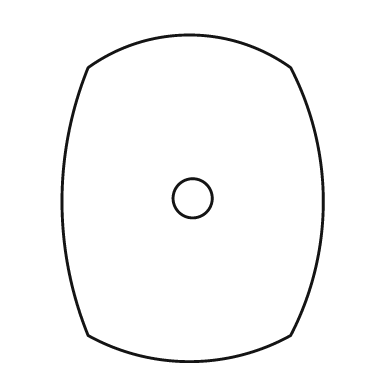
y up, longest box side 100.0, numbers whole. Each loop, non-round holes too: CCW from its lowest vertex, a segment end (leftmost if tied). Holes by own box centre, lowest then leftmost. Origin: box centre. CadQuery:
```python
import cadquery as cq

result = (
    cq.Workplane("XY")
    .moveTo(-32.0, -42.0)
    .threePointArc((-1.0, -50.0), (30.0, -42.0))
    .threePointArc((40.0, -1.0), (30.0, 40.0))
    .threePointArc((-1.0, 50.0), (-32.0, 40.0))
    .threePointArc((-40.0, -1.0), (-32.0, -42.0))
    .close()
    .moveTo(0.0, 0.0)
    .circle(6.0)
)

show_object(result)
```